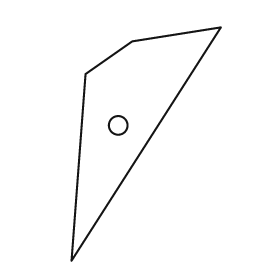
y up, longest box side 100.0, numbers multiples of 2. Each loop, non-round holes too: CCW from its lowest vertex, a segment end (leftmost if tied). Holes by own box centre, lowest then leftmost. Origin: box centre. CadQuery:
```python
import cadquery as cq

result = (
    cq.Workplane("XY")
    .moveTo(-32.0, -50.0)
    .lineTo(32.0, 50.0)
    .lineTo(-6.0, 44.0)
    .lineTo(-26.0, 30.0)
    .close()
    .moveTo(-12.0, 8.0)
    .circle(4.0)
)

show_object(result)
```